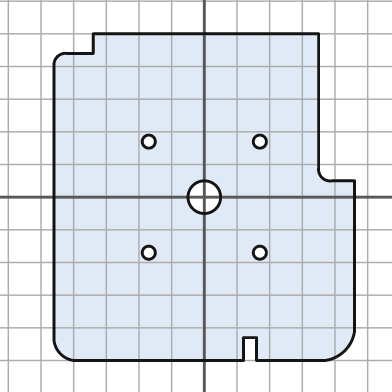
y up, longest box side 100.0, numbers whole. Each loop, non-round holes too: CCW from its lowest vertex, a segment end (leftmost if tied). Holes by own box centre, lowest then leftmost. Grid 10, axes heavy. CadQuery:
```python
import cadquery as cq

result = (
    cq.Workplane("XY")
    .moveTo(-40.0, -50.0)
    .lineTo(12.0, -50.0)
    .lineTo(12.0, -43.0)
    .lineTo(16.0, -43.0)
    .lineTo(16.0, -50.0)
    .lineTo(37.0, -50.0)
    .threePointArc((43.0, -47.0), (46.0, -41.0))
    .lineTo(46.0, 5.0)
    .lineTo(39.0, 5.0)
    .threePointArc((36.0, 6.0), (35.0, 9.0))
    .lineTo(35.0, 50.0)
    .lineTo(-34.0, 50.0)
    .lineTo(-34.0, 44.0)
    .lineTo(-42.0, 44.0)
    .threePointArc((-45.0, 43.0), (-46.0, 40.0))
    .lineTo(-46.0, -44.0)
    .threePointArc((-44.0, -48.0), (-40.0, -50.0))
    .close()
    .moveTo(-17.0, -17.0)
    .circle(2.0)
    .moveTo(17.0, -17.0)
    .circle(2.0)
    .moveTo(0.0, 0.0)
    .circle(5.0)
    .moveTo(-17.0, 17.0)
    .circle(2.0)
    .moveTo(17.0, 17.0)
    .circle(2.0)
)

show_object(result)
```